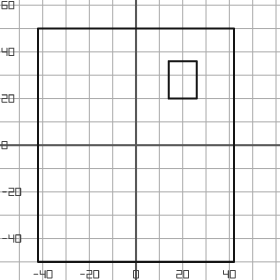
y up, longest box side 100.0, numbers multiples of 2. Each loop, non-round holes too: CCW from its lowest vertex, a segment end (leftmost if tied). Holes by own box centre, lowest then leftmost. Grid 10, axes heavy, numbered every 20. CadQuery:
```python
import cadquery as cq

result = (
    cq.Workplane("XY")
    .moveTo(-42.0, -50.0)
    .lineTo(42.0, -50.0)
    .lineTo(42.0, 50.0)
    .lineTo(-42.0, 50.0)
    .close()
    .moveTo(14.0, 20.0)
    .lineTo(26.0, 20.0)
    .lineTo(26.0, 36.0)
    .lineTo(14.0, 36.0)
    .close()
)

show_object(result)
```